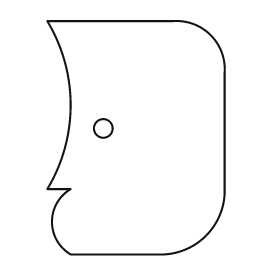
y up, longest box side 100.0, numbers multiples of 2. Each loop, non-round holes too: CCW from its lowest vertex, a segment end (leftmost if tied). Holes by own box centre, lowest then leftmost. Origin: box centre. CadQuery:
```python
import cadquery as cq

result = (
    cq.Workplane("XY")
    .moveTo(-28.0, -50.0)
    .lineTo(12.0, -50.0)
    .threePointArc((30.0, -42.0), (38.0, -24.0))
    .lineTo(38.0, 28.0)
    .threePointArc((32.0, 44.0), (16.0, 50.0))
    .lineTo(-38.0, 50.0)
    .threePointArc((-28.0, 14.0), (-38.0, -22.0))
    .lineTo(-28.0, -22.0)
    .threePointArc((-36.0, -36.0), (-28.0, -50.0))
    .close()
    .moveTo(-14.0, 4.0)
    .circle(4.0)
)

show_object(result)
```